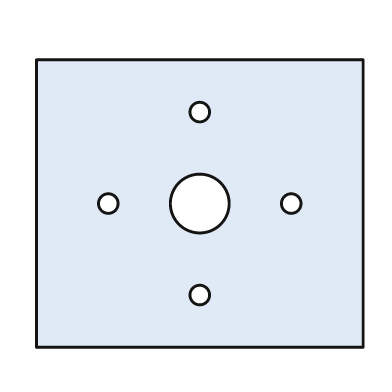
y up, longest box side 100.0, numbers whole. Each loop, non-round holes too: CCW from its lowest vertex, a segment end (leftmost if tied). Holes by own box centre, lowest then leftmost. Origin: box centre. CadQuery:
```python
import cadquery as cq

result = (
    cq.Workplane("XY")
    .moveTo(-50.0, -44.0)
    .lineTo(50.0, -44.0)
    .lineTo(50.0, 44.0)
    .lineTo(-50.0, 44.0)
    .close()
    .moveTo(0.0, -28.0)
    .circle(3.0)
    .moveTo(-28.0, 0.0)
    .circle(3.0)
    .moveTo(0.0, 0.0)
    .circle(9.0)
    .moveTo(28.0, 0.0)
    .circle(3.0)
    .moveTo(0.0, 28.0)
    .circle(3.0)
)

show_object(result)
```